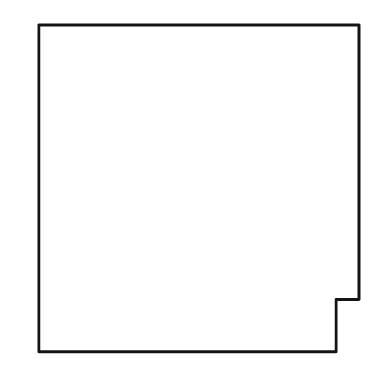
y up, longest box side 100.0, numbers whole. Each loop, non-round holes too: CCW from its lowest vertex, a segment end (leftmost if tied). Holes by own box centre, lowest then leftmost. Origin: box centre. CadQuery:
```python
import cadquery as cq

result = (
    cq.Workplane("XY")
    .moveTo(-49.0, -50.0)
    .lineTo(42.0, -50.0)
    .lineTo(42.0, -34.0)
    .lineTo(49.0, -34.0)
    .lineTo(49.0, 50.0)
    .lineTo(-49.0, 50.0)
    .close()
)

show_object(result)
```